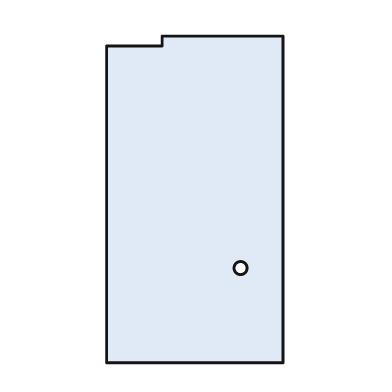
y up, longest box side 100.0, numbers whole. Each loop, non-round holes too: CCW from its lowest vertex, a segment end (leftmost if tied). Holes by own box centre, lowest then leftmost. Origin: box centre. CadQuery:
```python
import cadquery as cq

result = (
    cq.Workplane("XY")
    .moveTo(-27.0, -50.0)
    .lineTo(27.0, -50.0)
    .lineTo(27.0, 50.0)
    .lineTo(-10.0, 50.0)
    .lineTo(-10.0, 47.0)
    .lineTo(-27.0, 47.0)
    .close()
    .moveTo(14.0, -21.0)
    .circle(2.0)
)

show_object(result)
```